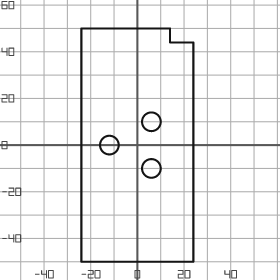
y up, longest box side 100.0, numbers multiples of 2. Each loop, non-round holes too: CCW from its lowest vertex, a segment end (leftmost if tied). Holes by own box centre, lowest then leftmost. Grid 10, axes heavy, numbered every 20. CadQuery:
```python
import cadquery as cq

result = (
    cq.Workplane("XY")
    .moveTo(-24.0, -50.0)
    .lineTo(24.0, -50.0)
    .lineTo(24.0, 44.0)
    .lineTo(14.0, 44.0)
    .lineTo(14.0, 50.0)
    .lineTo(-24.0, 50.0)
    .close()
    .moveTo(6.0, -10.0)
    .circle(4.0)
    .moveTo(-12.0, 0.0)
    .circle(4.0)
    .moveTo(6.0, 10.0)
    .circle(4.0)
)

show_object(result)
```